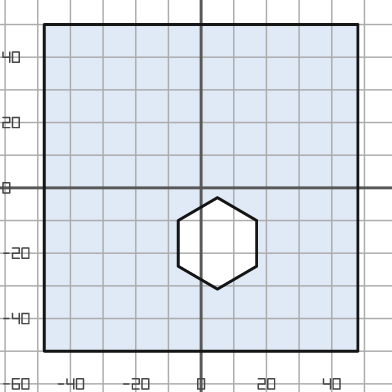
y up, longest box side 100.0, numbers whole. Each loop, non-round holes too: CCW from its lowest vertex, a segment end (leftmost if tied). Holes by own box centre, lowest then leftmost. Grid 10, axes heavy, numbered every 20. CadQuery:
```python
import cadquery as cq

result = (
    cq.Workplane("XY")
    .moveTo(-48.0, -50.0)
    .lineTo(48.0, -50.0)
    .lineTo(48.0, 50.0)
    .lineTo(-48.0, 50.0)
    .close()
    .moveTo(5.0, -31.0)
    .lineTo(17.0, -24.0)
    .lineTo(17.0, -10.0)
    .lineTo(5.0, -3.0)
    .lineTo(-7.0, -10.0)
    .lineTo(-7.0, -24.0)
    .close()
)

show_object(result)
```